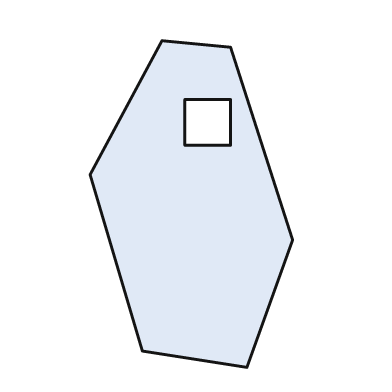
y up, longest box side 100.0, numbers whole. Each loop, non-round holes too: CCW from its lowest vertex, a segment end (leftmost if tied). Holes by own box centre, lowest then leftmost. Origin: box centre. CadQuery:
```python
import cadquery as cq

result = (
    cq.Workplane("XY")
    .moveTo(17.0, -50.0)
    .lineTo(31.0, -11.0)
    .lineTo(12.0, 48.0)
    .lineTo(-9.0, 50.0)
    .lineTo(-31.0, 9.0)
    .lineTo(-15.0, -45.0)
    .close()
    .moveTo(-2.0, 18.0)
    .lineTo(12.0, 18.0)
    .lineTo(12.0, 32.0)
    .lineTo(-2.0, 32.0)
    .close()
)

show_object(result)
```